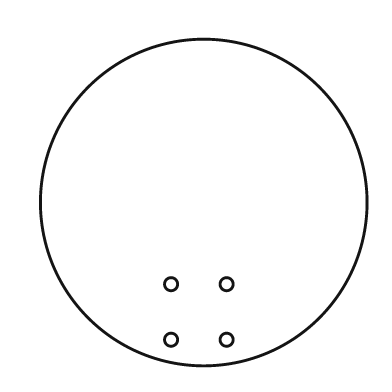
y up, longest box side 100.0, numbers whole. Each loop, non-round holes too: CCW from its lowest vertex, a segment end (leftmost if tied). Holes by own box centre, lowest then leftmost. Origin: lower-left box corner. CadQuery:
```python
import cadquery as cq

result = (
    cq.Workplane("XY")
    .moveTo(50.0, 50.0)
    .circle(50.0)
    .moveTo(40.0, 8.0)
    .circle(2.0)
    .moveTo(57.0, 8.0)
    .circle(2.0)
    .moveTo(40.0, 25.0)
    .circle(2.0)
    .moveTo(57.0, 25.0)
    .circle(2.0)
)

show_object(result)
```